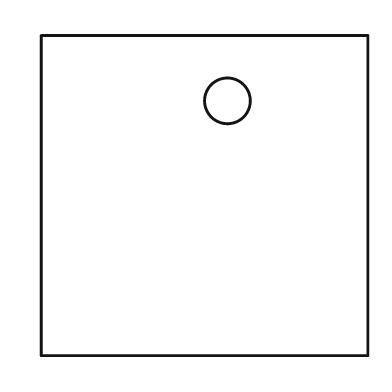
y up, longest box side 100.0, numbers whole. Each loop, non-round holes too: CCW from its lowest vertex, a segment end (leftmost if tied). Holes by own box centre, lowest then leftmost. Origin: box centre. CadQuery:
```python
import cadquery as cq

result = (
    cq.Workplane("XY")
    .moveTo(-50.0, -49.0)
    .lineTo(50.0, -49.0)
    .lineTo(50.0, 49.0)
    .lineTo(-50.0, 49.0)
    .close()
    .moveTo(7.0, 29.0)
    .circle(7.0)
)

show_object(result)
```